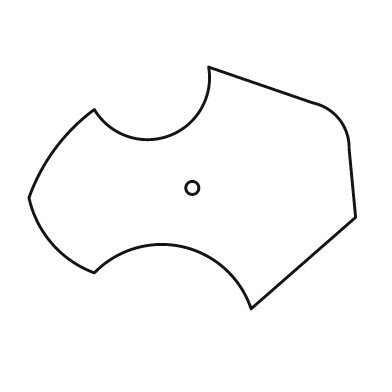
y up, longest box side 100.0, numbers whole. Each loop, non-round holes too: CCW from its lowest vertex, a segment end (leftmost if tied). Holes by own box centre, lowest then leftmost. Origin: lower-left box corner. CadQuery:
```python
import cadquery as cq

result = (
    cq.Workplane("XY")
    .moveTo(68.0, 0.0)
    .lineTo(100.0, 28.0)
    .lineTo(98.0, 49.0)
    .threePointArc((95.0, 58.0), (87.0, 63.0))
    .lineTo(55.0, 74.0)
    .threePointArc((43.0, 53.0), (20.0, 61.0))
    .threePointArc((8.0, 49.0), (0.0, 34.0))
    .threePointArc((7.0, 20.0), (20.0, 11.0))
    .threePointArc((47.0, 19.0), (68.0, 0.0))
    .close()
    .moveTo(50.0, 37.0)
    .circle(2.0)
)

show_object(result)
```